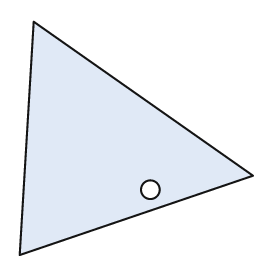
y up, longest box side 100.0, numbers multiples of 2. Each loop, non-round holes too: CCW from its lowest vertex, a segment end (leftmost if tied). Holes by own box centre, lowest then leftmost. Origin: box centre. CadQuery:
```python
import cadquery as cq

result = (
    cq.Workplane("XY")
    .moveTo(-50.0, -50.0)
    .lineTo(50.0, -16.0)
    .lineTo(-44.0, 50.0)
    .close()
    .moveTo(6.0, -22.0)
    .circle(4.0)
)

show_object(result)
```